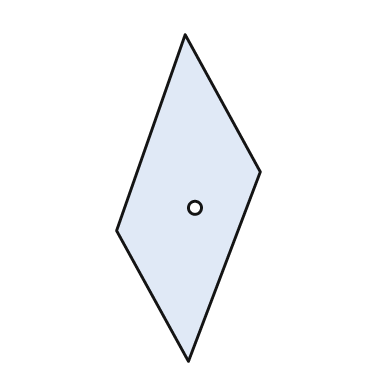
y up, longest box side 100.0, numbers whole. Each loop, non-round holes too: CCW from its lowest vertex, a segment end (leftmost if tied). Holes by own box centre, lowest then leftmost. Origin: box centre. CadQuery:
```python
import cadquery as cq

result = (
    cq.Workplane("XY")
    .moveTo(0.0, -50.0)
    .lineTo(22.0, 8.0)
    .lineTo(-1.0, 50.0)
    .lineTo(-22.0, -10.0)
    .close()
    .moveTo(2.0, -3.0)
    .circle(2.0)
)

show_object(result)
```